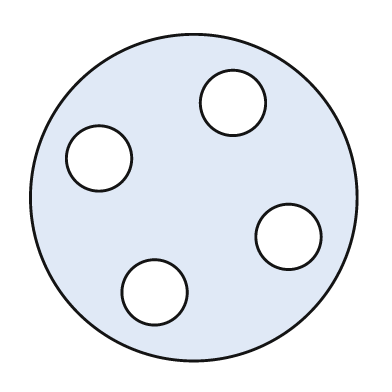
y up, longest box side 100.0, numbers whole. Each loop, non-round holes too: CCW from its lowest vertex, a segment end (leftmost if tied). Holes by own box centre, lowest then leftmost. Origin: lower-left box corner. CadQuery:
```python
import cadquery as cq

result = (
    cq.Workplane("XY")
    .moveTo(50.0, 50.0)
    .circle(50.0)
    .moveTo(38.0, 21.0)
    .circle(10.0)
    .moveTo(79.0, 38.0)
    .circle(10.0)
    .moveTo(21.0, 62.0)
    .circle(10.0)
    .moveTo(62.0, 79.0)
    .circle(10.0)
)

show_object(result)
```